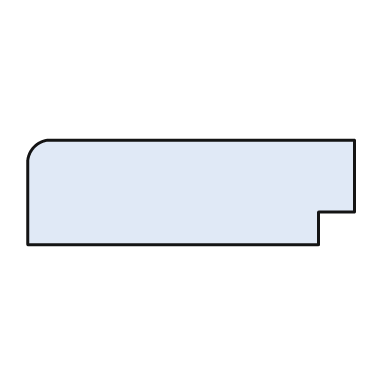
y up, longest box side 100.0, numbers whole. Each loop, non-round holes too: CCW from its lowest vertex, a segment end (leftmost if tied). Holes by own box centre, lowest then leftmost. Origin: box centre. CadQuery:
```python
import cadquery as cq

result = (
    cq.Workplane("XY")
    .moveTo(-50.0, -16.0)
    .lineTo(39.0, -16.0)
    .lineTo(39.0, -6.0)
    .lineTo(50.0, -6.0)
    .lineTo(50.0, 16.0)
    .lineTo(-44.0, 16.0)
    .threePointArc((-48.0, 14.0), (-50.0, 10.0))
    .close()
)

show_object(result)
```